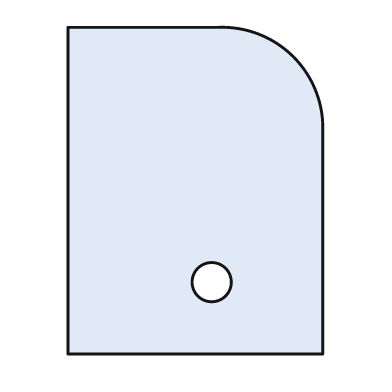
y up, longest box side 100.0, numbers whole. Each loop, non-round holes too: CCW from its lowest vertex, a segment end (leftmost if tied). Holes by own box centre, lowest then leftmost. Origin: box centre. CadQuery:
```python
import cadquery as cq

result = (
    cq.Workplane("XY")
    .moveTo(-39.0, -50.0)
    .lineTo(39.0, -50.0)
    .lineTo(39.0, 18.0)
    .threePointArc((30.0, 41.0), (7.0, 50.0))
    .lineTo(-39.0, 50.0)
    .close()
    .moveTo(5.0, -28.0)
    .circle(6.0)
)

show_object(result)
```